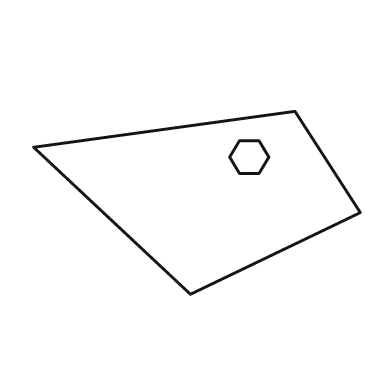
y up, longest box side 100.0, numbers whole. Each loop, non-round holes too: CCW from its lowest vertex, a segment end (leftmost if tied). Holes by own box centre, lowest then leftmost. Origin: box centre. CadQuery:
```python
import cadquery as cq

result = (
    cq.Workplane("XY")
    .moveTo(-2.0, -28.0)
    .lineTo(50.0, -3.0)
    .lineTo(30.0, 28.0)
    .lineTo(-50.0, 17.0)
    .close()
    .moveTo(13.0, 9.0)
    .lineTo(19.0, 9.0)
    .lineTo(22.0, 14.0)
    .lineTo(19.0, 19.0)
    .lineTo(13.0, 19.0)
    .lineTo(10.0, 14.0)
    .close()
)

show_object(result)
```